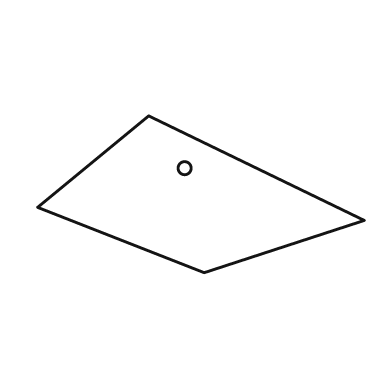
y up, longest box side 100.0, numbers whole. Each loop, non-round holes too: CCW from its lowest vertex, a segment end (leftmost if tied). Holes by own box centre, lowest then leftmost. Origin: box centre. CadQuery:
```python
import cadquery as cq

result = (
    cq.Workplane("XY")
    .moveTo(1.0, -24.0)
    .lineTo(50.0, -8.0)
    .lineTo(-16.0, 24.0)
    .lineTo(-50.0, -4.0)
    .close()
    .moveTo(-5.0, 8.0)
    .circle(2.0)
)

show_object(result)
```